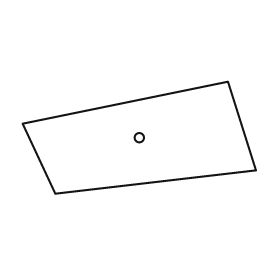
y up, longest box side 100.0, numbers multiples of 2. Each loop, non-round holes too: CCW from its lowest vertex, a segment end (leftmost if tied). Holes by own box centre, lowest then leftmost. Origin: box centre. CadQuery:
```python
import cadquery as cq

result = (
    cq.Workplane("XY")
    .moveTo(-36.0, -24.0)
    .lineTo(50.0, -14.0)
    .lineTo(38.0, 24.0)
    .lineTo(-50.0, 6.0)
    .close()
    .moveTo(0.0, 0.0)
    .circle(2.0)
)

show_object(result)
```